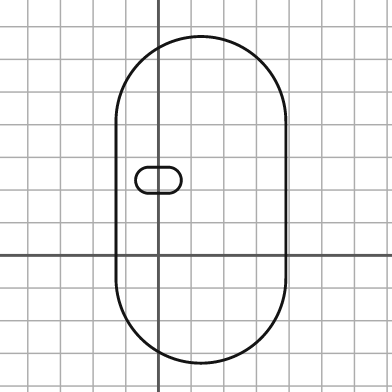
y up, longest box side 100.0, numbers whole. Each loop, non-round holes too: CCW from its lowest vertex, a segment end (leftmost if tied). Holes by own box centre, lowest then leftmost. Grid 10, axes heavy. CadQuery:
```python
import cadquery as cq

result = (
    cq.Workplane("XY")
    .moveTo(-13.0, -7.0)
    .threePointArc((13.0, -33.0), (39.0, -7.0))
    .lineTo(39.0, 41.0)
    .threePointArc((13.0, 67.0), (-13.0, 41.0))
    .close()
    .moveTo(-3.0, 19.0)
    .lineTo(3.0, 19.0)
    .threePointArc((7.0, 23.0), (3.0, 27.0))
    .lineTo(-3.0, 27.0)
    .threePointArc((-7.0, 23.0), (-3.0, 19.0))
    .close()
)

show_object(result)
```